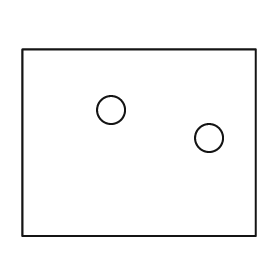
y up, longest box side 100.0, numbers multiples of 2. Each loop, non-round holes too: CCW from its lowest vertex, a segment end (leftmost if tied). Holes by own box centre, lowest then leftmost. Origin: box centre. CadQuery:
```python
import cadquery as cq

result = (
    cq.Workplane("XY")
    .moveTo(-50.0, -40.0)
    .lineTo(50.0, -40.0)
    .lineTo(50.0, 40.0)
    .lineTo(-50.0, 40.0)
    .close()
    .moveTo(30.0, 2.0)
    .circle(6.0)
    .moveTo(-12.0, 14.0)
    .circle(6.0)
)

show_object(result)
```